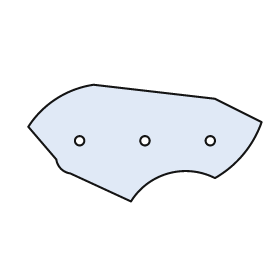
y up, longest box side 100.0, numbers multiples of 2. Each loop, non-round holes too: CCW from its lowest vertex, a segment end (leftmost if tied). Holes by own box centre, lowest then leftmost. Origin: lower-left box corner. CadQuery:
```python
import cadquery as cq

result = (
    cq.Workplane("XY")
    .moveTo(44.0, 0.0)
    .threePointArc((60.0, 12.0), (80.0, 10.0))
    .threePointArc((92.0, 20.0), (100.0, 34.0))
    .lineTo(80.0, 44.0)
    .lineTo(28.0, 50.0)
    .threePointArc((12.0, 44.0), (0.0, 32.0))
    .lineTo(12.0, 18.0)
    .threePointArc((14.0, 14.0), (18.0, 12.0))
    .close()
    .moveTo(22.0, 26.0)
    .circle(2.0)
    .moveTo(50.0, 26.0)
    .circle(2.0)
    .moveTo(78.0, 26.0)
    .circle(2.0)
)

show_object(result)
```